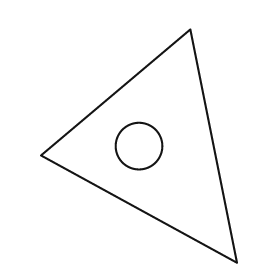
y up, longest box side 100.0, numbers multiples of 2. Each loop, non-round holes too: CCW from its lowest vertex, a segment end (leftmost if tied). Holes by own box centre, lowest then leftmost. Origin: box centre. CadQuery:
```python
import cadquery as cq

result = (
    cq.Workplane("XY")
    .moveTo(42.0, -50.0)
    .lineTo(22.0, 50.0)
    .lineTo(-42.0, -4.0)
    .close()
    .moveTo(0.0, 0.0)
    .circle(10.0)
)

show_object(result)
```